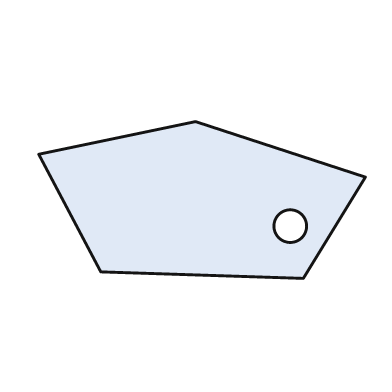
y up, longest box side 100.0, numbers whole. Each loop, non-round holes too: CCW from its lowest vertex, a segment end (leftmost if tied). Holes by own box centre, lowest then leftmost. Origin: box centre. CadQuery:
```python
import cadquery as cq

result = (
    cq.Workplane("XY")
    .moveTo(31.0, -24.0)
    .lineTo(50.0, 7.0)
    .lineTo(-2.0, 24.0)
    .lineTo(-50.0, 14.0)
    .lineTo(-31.0, -22.0)
    .close()
    .moveTo(27.0, -8.0)
    .circle(5.0)
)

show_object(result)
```